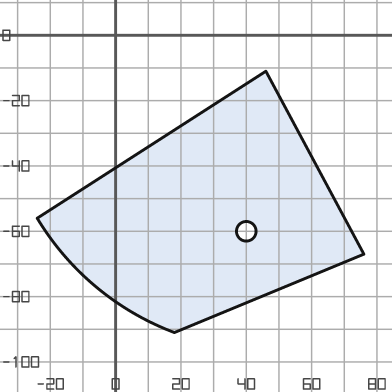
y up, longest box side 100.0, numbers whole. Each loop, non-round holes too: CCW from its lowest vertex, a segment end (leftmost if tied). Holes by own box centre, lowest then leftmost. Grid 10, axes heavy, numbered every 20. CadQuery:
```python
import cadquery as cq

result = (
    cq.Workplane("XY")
    .moveTo(18.0, -91.0)
    .lineTo(76.0, -67.0)
    .lineTo(46.0, -11.0)
    .lineTo(-24.0, -56.0)
    .threePointArc((-6.0, -77.0), (18.0, -91.0))
    .close()
    .moveTo(40.0, -60.0)
    .circle(3.0)
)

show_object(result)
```